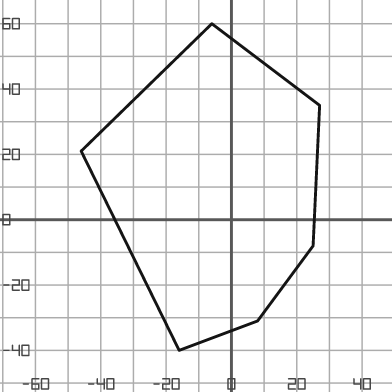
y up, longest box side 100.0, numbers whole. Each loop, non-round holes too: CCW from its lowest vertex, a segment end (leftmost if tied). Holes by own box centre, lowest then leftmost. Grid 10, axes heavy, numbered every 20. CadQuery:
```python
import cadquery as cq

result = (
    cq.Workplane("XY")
    .moveTo(-16.0, -40.0)
    .lineTo(8.0, -31.0)
    .lineTo(25.0, -8.0)
    .lineTo(27.0, 35.0)
    .lineTo(-6.0, 60.0)
    .lineTo(-46.0, 21.0)
    .close()
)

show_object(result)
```